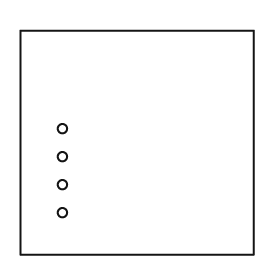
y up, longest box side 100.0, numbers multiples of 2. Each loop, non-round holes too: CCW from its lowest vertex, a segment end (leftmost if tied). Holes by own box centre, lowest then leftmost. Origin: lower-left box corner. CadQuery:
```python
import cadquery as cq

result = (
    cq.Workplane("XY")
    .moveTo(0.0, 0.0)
    .lineTo(100.0, 0.0)
    .lineTo(100.0, 96.0)
    .lineTo(0.0, 96.0)
    .close()
    .moveTo(18.0, 18.0)
    .circle(2.0)
    .moveTo(18.0, 30.0)
    .circle(2.0)
    .moveTo(18.0, 42.0)
    .circle(2.0)
    .moveTo(18.0, 54.0)
    .circle(2.0)
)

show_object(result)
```